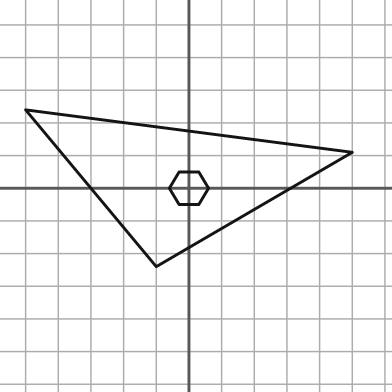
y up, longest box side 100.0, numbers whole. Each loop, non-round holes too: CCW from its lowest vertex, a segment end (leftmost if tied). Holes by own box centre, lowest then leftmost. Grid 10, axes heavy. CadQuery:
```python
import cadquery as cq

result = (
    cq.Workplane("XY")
    .moveTo(-10.0, -24.0)
    .lineTo(50.0, 11.0)
    .lineTo(-50.0, 24.0)
    .close()
    .moveTo(-3.0, -5.0)
    .lineTo(3.0, -5.0)
    .lineTo(6.0, 0.0)
    .lineTo(3.0, 5.0)
    .lineTo(-3.0, 5.0)
    .lineTo(-6.0, 0.0)
    .close()
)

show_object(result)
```